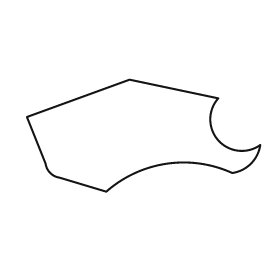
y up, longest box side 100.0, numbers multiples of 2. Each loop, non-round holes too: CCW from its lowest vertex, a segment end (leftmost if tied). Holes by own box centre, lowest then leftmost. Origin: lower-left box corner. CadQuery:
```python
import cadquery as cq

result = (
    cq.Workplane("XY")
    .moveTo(34.0, 0.0)
    .threePointArc((60.0, 12.0), (88.0, 8.0))
    .threePointArc((96.0, 12.0), (100.0, 20.0))
    .threePointArc((82.0, 22.0), (82.0, 40.0))
    .lineTo(44.0, 48.0)
    .lineTo(0.0, 32.0)
    .lineTo(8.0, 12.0)
    .threePointArc((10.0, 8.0), (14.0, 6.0))
    .close()
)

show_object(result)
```